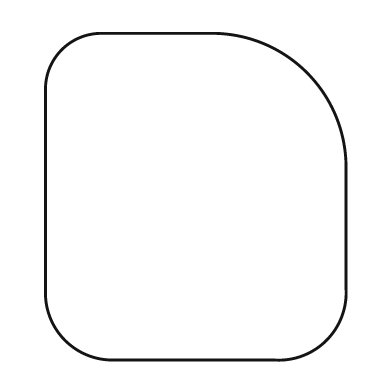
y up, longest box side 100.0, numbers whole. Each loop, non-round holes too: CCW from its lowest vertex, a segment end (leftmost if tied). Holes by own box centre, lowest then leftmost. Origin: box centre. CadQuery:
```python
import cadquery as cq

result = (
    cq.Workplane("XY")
    .moveTo(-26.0, -50.0)
    .lineTo(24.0, -50.0)
    .threePointArc((40.0, -44.0), (46.0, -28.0))
    .lineTo(46.0, 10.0)
    .threePointArc((34.0, 38.0), (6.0, 50.0))
    .lineTo(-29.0, 50.0)
    .threePointArc((-41.0, 45.0), (-46.0, 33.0))
    .lineTo(-46.0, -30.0)
    .threePointArc((-40.0, -44.0), (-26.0, -50.0))
    .close()
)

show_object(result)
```